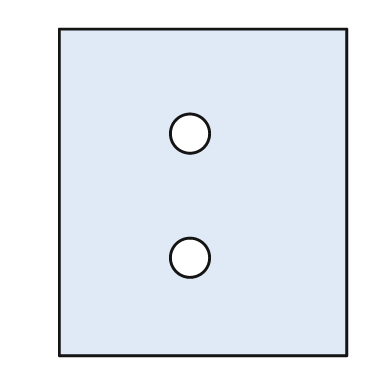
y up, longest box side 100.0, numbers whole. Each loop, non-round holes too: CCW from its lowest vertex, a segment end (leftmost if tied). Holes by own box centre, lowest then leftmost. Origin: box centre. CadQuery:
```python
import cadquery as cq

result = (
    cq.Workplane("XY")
    .moveTo(-44.0, -50.0)
    .lineTo(44.0, -50.0)
    .lineTo(44.0, 50.0)
    .lineTo(-44.0, 50.0)
    .close()
    .moveTo(-4.0, -20.0)
    .circle(6.0)
    .moveTo(-4.0, 18.0)
    .circle(6.0)
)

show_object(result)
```